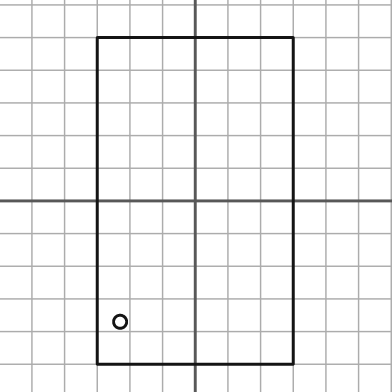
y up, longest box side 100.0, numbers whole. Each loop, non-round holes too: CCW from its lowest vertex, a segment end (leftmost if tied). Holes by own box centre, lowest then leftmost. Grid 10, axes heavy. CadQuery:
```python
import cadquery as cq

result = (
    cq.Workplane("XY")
    .moveTo(-30.0, -50.0)
    .lineTo(30.0, -50.0)
    .lineTo(30.0, 50.0)
    .lineTo(-30.0, 50.0)
    .close()
    .moveTo(-23.0, -37.0)
    .circle(2.0)
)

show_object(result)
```